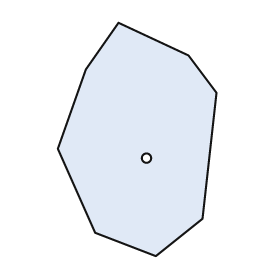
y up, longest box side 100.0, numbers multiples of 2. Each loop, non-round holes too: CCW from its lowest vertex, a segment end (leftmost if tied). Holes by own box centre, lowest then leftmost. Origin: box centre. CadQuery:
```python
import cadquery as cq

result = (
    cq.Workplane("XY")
    .moveTo(8.0, -50.0)
    .lineTo(28.0, -34.0)
    .lineTo(34.0, 20.0)
    .lineTo(22.0, 36.0)
    .lineTo(-8.0, 50.0)
    .lineTo(-22.0, 30.0)
    .lineTo(-34.0, -4.0)
    .lineTo(-18.0, -40.0)
    .close()
    .moveTo(4.0, -8.0)
    .circle(2.0)
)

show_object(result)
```